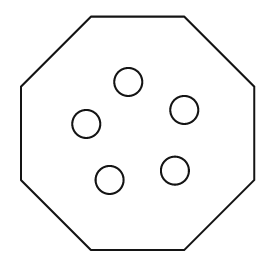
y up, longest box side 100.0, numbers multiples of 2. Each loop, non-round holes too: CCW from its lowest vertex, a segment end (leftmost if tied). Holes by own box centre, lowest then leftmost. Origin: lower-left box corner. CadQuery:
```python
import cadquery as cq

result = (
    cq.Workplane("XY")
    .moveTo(30.0, 0.0)
    .lineTo(70.0, 0.0)
    .lineTo(100.0, 30.0)
    .lineTo(100.0, 70.0)
    .lineTo(70.0, 100.0)
    .lineTo(30.0, 100.0)
    .lineTo(0.0, 70.0)
    .lineTo(0.0, 30.0)
    .close()
    .moveTo(38.0, 30.0)
    .circle(6.0)
    .moveTo(66.0, 34.0)
    .circle(6.0)
    .moveTo(28.0, 54.0)
    .circle(6.0)
    .moveTo(70.0, 60.0)
    .circle(6.0)
    .moveTo(46.0, 72.0)
    .circle(6.0)
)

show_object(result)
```